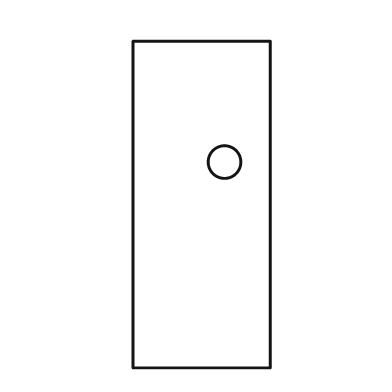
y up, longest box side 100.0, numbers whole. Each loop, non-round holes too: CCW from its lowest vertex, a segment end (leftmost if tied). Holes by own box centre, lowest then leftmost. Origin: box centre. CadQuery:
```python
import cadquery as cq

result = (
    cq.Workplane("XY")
    .moveTo(-21.0, -50.0)
    .lineTo(21.0, -50.0)
    .lineTo(21.0, 50.0)
    .lineTo(-21.0, 50.0)
    .close()
    .moveTo(7.0, 13.0)
    .circle(5.0)
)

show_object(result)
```